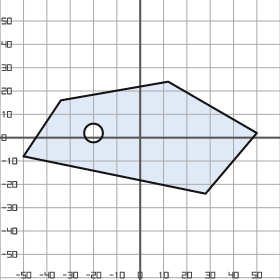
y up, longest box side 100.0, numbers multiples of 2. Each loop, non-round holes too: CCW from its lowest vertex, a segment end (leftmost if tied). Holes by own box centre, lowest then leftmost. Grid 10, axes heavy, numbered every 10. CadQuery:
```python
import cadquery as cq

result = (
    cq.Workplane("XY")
    .moveTo(28.0, -24.0)
    .lineTo(50.0, 2.0)
    .lineTo(12.0, 24.0)
    .lineTo(-34.0, 16.0)
    .lineTo(-50.0, -8.0)
    .close()
    .moveTo(-20.0, 2.0)
    .circle(4.0)
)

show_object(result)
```